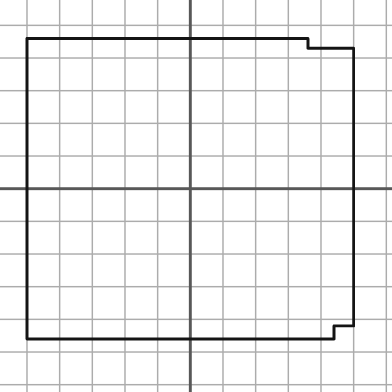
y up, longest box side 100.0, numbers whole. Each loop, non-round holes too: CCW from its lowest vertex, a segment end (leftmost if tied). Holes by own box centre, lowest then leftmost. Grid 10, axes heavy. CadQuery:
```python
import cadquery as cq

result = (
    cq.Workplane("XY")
    .moveTo(-50.0, -46.0)
    .lineTo(44.0, -46.0)
    .lineTo(44.0, -42.0)
    .lineTo(50.0, -42.0)
    .lineTo(50.0, 43.0)
    .lineTo(36.0, 43.0)
    .lineTo(36.0, 46.0)
    .lineTo(-50.0, 46.0)
    .close()
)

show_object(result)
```